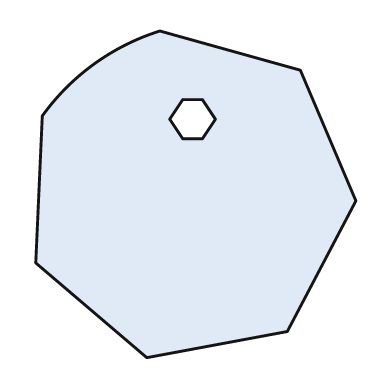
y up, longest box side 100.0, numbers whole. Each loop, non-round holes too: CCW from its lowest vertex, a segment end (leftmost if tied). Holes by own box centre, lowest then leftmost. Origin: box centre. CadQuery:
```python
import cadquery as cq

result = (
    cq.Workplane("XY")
    .moveTo(-15.0, -50.0)
    .lineTo(28.0, -42.0)
    .lineTo(49.0, -2.0)
    .lineTo(32.0, 38.0)
    .lineTo(-11.0, 50.0)
    .threePointArc((-31.0, 40.0), (-47.0, 24.0))
    .lineTo(-49.0, -21.0)
    .close()
    .moveTo(-4.0, 17.0)
    .lineTo(2.0, 17.0)
    .lineTo(6.0, 23.0)
    .lineTo(2.0, 29.0)
    .lineTo(-4.0, 29.0)
    .lineTo(-8.0, 23.0)
    .close()
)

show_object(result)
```